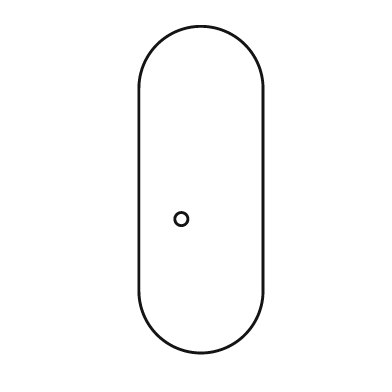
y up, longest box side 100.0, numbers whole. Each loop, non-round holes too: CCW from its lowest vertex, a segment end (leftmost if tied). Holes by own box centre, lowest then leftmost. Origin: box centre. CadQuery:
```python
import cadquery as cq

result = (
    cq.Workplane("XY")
    .moveTo(-19.0, -31.0)
    .threePointArc((0.0, -50.0), (19.0, -31.0))
    .lineTo(19.0, 31.0)
    .threePointArc((0.0, 50.0), (-19.0, 31.0))
    .close()
    .moveTo(-6.0, -9.0)
    .circle(2.0)
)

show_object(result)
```